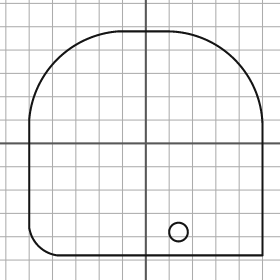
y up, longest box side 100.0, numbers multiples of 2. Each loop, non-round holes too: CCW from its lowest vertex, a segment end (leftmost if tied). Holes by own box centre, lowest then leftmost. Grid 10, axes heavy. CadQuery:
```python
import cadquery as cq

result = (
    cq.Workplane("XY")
    .moveTo(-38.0, -48.0)
    .lineTo(50.0, -48.0)
    .lineTo(50.0, 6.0)
    .threePointArc((38.0, 36.0), (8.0, 48.0))
    .lineTo(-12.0, 48.0)
    .threePointArc((-38.0, 36.0), (-50.0, 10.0))
    .lineTo(-50.0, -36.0)
    .threePointArc((-46.0, -44.0), (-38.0, -48.0))
    .close()
    .moveTo(14.0, -38.0)
    .circle(4.0)
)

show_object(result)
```